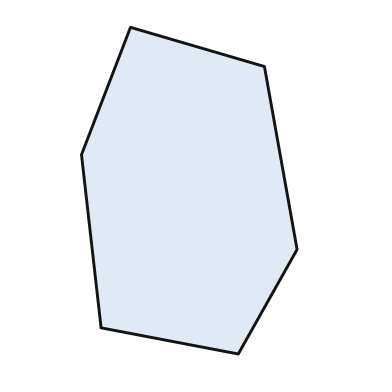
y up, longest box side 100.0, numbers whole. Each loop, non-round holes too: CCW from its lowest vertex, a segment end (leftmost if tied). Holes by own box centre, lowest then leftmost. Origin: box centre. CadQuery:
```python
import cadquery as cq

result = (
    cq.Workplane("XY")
    .moveTo(15.0, -50.0)
    .lineTo(33.0, -18.0)
    .lineTo(23.0, 38.0)
    .lineTo(-18.0, 50.0)
    .lineTo(-33.0, 11.0)
    .lineTo(-27.0, -42.0)
    .close()
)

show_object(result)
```